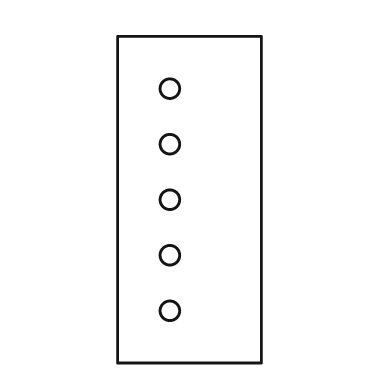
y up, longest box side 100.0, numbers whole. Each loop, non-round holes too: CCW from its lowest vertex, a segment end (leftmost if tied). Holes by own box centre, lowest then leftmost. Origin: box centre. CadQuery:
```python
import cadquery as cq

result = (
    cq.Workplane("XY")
    .moveTo(-22.0, -50.0)
    .lineTo(22.0, -50.0)
    .lineTo(22.0, 50.0)
    .lineTo(-22.0, 50.0)
    .close()
    .moveTo(-6.0, -34.0)
    .circle(3.0)
    .moveTo(-6.0, -17.0)
    .circle(3.0)
    .moveTo(-6.0, 0.0)
    .circle(3.0)
    .moveTo(-6.0, 17.0)
    .circle(3.0)
    .moveTo(-6.0, 34.0)
    .circle(3.0)
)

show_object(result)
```